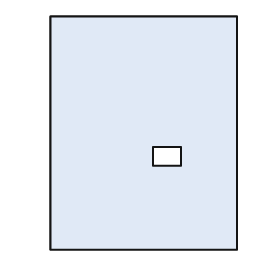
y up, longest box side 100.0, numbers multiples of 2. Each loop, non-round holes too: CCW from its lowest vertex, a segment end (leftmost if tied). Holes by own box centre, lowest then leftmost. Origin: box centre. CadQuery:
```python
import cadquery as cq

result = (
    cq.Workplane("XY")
    .moveTo(-40.0, -50.0)
    .lineTo(40.0, -50.0)
    .lineTo(40.0, 50.0)
    .lineTo(-40.0, 50.0)
    .close()
    .moveTo(4.0, -14.0)
    .lineTo(16.0, -14.0)
    .lineTo(16.0, -6.0)
    .lineTo(4.0, -6.0)
    .close()
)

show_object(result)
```